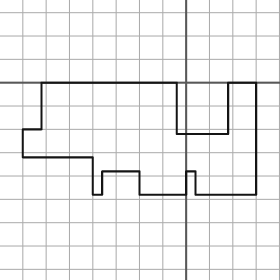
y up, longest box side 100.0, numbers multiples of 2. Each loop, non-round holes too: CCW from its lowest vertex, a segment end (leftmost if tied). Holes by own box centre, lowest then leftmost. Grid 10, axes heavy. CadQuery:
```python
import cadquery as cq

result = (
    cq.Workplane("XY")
    .moveTo(-40.0, -48.0)
    .lineTo(-36.0, -48.0)
    .lineTo(-36.0, -38.0)
    .lineTo(-20.0, -38.0)
    .lineTo(-20.0, -48.0)
    .lineTo(0.0, -48.0)
    .lineTo(0.0, -38.0)
    .lineTo(4.0, -38.0)
    .lineTo(4.0, -48.0)
    .lineTo(30.0, -48.0)
    .lineTo(30.0, 0.0)
    .lineTo(18.0, 0.0)
    .lineTo(18.0, -22.0)
    .lineTo(-4.0, -22.0)
    .lineTo(-4.0, 0.0)
    .lineTo(-62.0, 0.0)
    .lineTo(-62.0, -20.0)
    .lineTo(-70.0, -20.0)
    .lineTo(-70.0, -32.0)
    .lineTo(-40.0, -32.0)
    .close()
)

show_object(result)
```